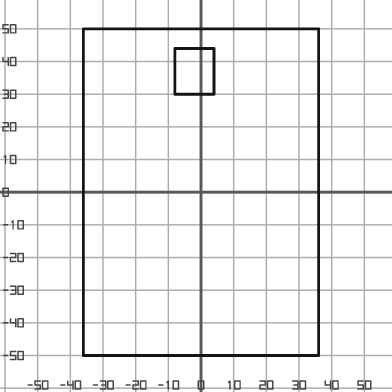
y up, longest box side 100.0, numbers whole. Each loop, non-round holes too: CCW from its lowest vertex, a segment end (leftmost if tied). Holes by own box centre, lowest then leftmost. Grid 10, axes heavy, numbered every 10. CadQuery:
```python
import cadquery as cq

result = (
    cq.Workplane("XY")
    .moveTo(-36.0, -50.0)
    .lineTo(36.0, -50.0)
    .lineTo(36.0, 50.0)
    .lineTo(-36.0, 50.0)
    .close()
    .moveTo(-8.0, 30.0)
    .lineTo(4.0, 30.0)
    .lineTo(4.0, 44.0)
    .lineTo(-8.0, 44.0)
    .close()
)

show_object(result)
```